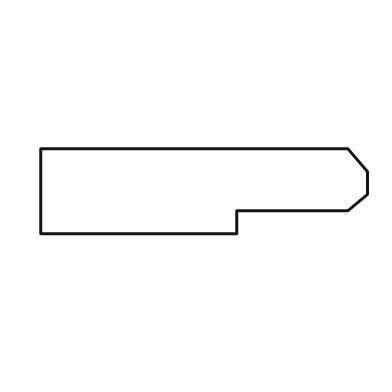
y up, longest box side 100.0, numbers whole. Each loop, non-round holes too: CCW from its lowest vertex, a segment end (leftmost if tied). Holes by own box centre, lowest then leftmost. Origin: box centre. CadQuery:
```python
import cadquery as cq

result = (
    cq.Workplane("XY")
    .moveTo(-50.0, -13.0)
    .lineTo(10.0, -13.0)
    .lineTo(10.0, -6.0)
    .lineTo(44.0, -6.0)
    .lineTo(50.0, -1.0)
    .lineTo(50.0, 6.0)
    .lineTo(44.0, 13.0)
    .lineTo(-50.0, 13.0)
    .close()
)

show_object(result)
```